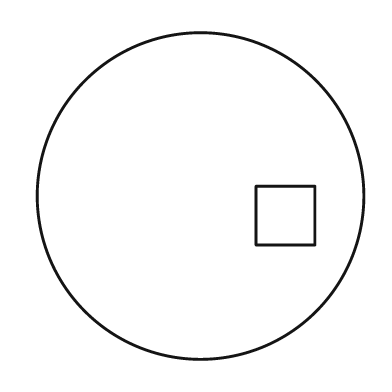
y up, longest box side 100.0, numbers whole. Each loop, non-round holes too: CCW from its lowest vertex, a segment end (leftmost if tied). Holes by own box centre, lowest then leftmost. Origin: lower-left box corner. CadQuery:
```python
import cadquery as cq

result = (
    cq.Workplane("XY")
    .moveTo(50.0, 50.0)
    .circle(50.0)
    .moveTo(67.0, 35.0)
    .lineTo(85.0, 35.0)
    .lineTo(85.0, 53.0)
    .lineTo(67.0, 53.0)
    .close()
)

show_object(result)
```